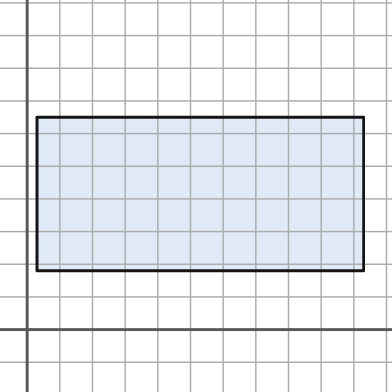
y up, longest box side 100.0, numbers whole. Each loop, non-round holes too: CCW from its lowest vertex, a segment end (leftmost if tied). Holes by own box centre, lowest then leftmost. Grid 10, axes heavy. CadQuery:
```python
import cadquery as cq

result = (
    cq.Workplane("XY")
    .moveTo(3.0, 18.0)
    .lineTo(103.0, 18.0)
    .lineTo(103.0, 65.0)
    .lineTo(3.0, 65.0)
    .close()
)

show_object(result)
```